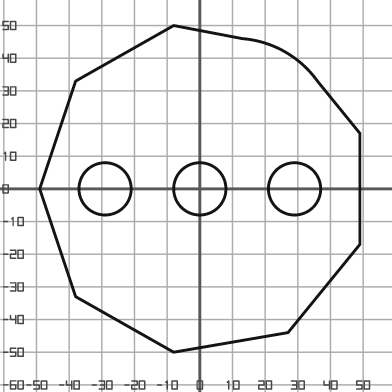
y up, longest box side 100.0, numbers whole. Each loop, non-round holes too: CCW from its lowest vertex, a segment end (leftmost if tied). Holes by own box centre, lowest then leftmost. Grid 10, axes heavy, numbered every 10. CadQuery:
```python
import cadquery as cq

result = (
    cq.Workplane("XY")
    .moveTo(-8.0, -50.0)
    .lineTo(27.0, -44.0)
    .lineTo(49.0, -17.0)
    .lineTo(49.0, 17.0)
    .lineTo(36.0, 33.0)
    .threePointArc((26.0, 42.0), (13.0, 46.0))
    .lineTo(-8.0, 50.0)
    .lineTo(-38.0, 33.0)
    .lineTo(-49.0, 0.0)
    .lineTo(-38.0, -33.0)
    .close()
    .moveTo(-29.0, 0.0)
    .circle(8.0)
    .moveTo(0.0, 0.0)
    .circle(8.0)
    .moveTo(29.0, 0.0)
    .circle(8.0)
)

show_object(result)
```